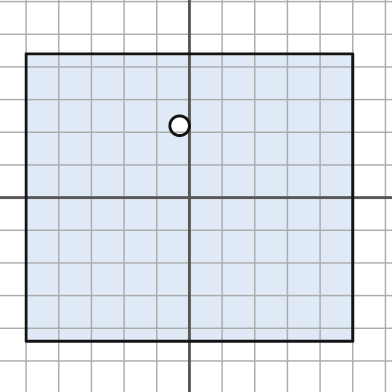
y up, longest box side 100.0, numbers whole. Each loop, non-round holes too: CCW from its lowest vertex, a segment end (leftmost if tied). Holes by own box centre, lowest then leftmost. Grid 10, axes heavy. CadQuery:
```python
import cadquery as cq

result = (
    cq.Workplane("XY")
    .moveTo(-50.0, -44.0)
    .lineTo(50.0, -44.0)
    .lineTo(50.0, 44.0)
    .lineTo(-50.0, 44.0)
    .close()
    .moveTo(-3.0, 22.0)
    .circle(3.0)
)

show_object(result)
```